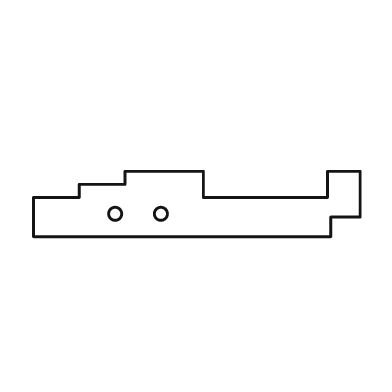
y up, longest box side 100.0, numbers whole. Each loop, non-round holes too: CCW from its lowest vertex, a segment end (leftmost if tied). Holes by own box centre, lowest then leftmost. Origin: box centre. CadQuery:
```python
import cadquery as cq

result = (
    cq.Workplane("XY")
    .moveTo(-50.0, -10.0)
    .lineTo(41.0, -10.0)
    .lineTo(41.0, -4.0)
    .lineTo(50.0, -4.0)
    .lineTo(50.0, 10.0)
    .lineTo(40.0, 10.0)
    .lineTo(40.0, 2.0)
    .lineTo(2.0, 2.0)
    .lineTo(2.0, 10.0)
    .lineTo(-22.0, 10.0)
    .lineTo(-22.0, 6.0)
    .lineTo(-36.0, 6.0)
    .lineTo(-36.0, 2.0)
    .lineTo(-50.0, 2.0)
    .close()
    .moveTo(-25.0, -3.0)
    .circle(2.0)
    .moveTo(-11.0, -3.0)
    .circle(2.0)
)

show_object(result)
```